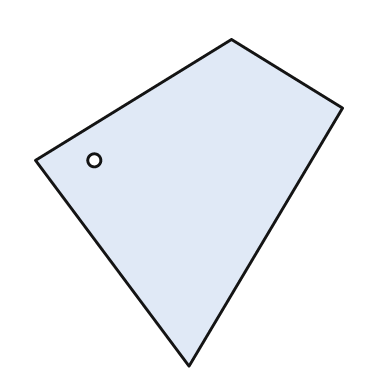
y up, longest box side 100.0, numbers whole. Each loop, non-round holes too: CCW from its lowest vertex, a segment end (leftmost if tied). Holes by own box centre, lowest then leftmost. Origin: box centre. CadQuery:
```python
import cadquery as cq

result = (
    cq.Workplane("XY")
    .moveTo(0.0, -50.0)
    .lineTo(47.0, 29.0)
    .lineTo(13.0, 50.0)
    .lineTo(-47.0, 13.0)
    .close()
    .moveTo(-29.0, 13.0)
    .circle(2.0)
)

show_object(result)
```